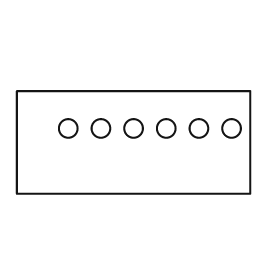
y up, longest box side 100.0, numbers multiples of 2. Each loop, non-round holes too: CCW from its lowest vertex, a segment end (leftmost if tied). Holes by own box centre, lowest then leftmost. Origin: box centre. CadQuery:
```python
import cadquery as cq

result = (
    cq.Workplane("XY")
    .moveTo(-50.0, -22.0)
    .lineTo(50.0, -22.0)
    .lineTo(50.0, 22.0)
    .lineTo(-50.0, 22.0)
    .close()
    .moveTo(-28.0, 6.0)
    .circle(4.0)
    .moveTo(-14.0, 6.0)
    .circle(4.0)
    .moveTo(0.0, 6.0)
    .circle(4.0)
    .moveTo(14.0, 6.0)
    .circle(4.0)
    .moveTo(28.0, 6.0)
    .circle(4.0)
    .moveTo(42.0, 6.0)
    .circle(4.0)
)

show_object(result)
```